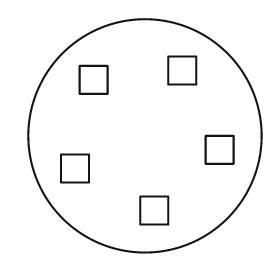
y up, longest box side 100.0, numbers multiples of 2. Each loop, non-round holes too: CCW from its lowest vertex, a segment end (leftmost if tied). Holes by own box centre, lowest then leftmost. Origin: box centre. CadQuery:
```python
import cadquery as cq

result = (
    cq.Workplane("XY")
    .moveTo(0.0, 0.0)
    .circle(50.0)
    .moveTo(-2.0, -38.0)
    .lineTo(10.0, -38.0)
    .lineTo(10.0, -26.0)
    .lineTo(-2.0, -26.0)
    .close()
    .moveTo(-36.0, -20.0)
    .lineTo(-24.0, -20.0)
    .lineTo(-24.0, -8.0)
    .lineTo(-36.0, -8.0)
    .close()
    .moveTo(26.0, -12.0)
    .lineTo(38.0, -12.0)
    .lineTo(38.0, 0.0)
    .lineTo(26.0, 0.0)
    .close()
    .moveTo(-28.0, 18.0)
    .lineTo(-16.0, 18.0)
    .lineTo(-16.0, 30.0)
    .lineTo(-28.0, 30.0)
    .close()
    .moveTo(10.0, 22.0)
    .lineTo(22.0, 22.0)
    .lineTo(22.0, 34.0)
    .lineTo(10.0, 34.0)
    .close()
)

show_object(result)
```